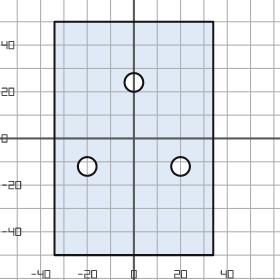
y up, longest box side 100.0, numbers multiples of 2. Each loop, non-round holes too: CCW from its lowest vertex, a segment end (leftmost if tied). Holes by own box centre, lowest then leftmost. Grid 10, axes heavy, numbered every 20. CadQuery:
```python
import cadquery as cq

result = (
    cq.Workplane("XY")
    .moveTo(-34.0, -50.0)
    .lineTo(34.0, -50.0)
    .lineTo(34.0, 50.0)
    .lineTo(-34.0, 50.0)
    .close()
    .moveTo(-20.0, -12.0)
    .circle(4.0)
    .moveTo(20.0, -12.0)
    .circle(4.0)
    .moveTo(0.0, 24.0)
    .circle(4.0)
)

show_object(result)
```